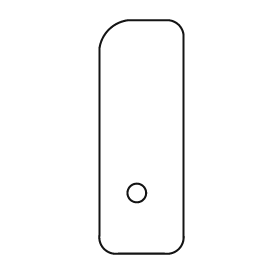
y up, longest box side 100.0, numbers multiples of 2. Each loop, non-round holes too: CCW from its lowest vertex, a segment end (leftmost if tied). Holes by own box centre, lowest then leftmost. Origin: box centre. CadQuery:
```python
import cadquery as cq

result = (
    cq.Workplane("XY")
    .moveTo(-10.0, -50.0)
    .lineTo(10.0, -50.0)
    .threePointArc((16.0, -48.0), (18.0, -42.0))
    .lineTo(18.0, 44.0)
    .threePointArc((16.0, 48.0), (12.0, 50.0))
    .lineTo(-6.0, 50.0)
    .threePointArc((-14.0, 46.0), (-18.0, 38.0))
    .lineTo(-18.0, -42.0)
    .threePointArc((-16.0, -48.0), (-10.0, -50.0))
    .close()
    .moveTo(-2.0, -24.0)
    .circle(4.0)
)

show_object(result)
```